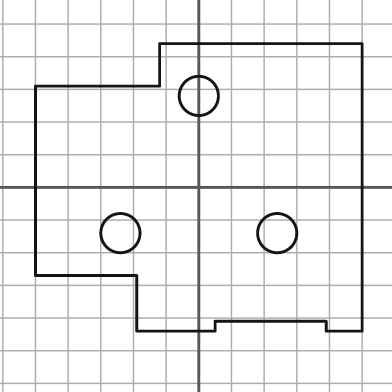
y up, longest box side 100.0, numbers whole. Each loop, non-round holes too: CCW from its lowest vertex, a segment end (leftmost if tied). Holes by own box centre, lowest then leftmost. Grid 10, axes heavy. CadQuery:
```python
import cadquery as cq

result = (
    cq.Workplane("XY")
    .moveTo(-19.0, -44.0)
    .lineTo(5.0, -44.0)
    .lineTo(5.0, -41.0)
    .lineTo(39.0, -41.0)
    .lineTo(39.0, -44.0)
    .lineTo(50.0, -44.0)
    .lineTo(50.0, 44.0)
    .lineTo(-12.0, 44.0)
    .lineTo(-12.0, 31.0)
    .lineTo(-50.0, 31.0)
    .lineTo(-50.0, -27.0)
    .lineTo(-19.0, -27.0)
    .close()
    .moveTo(-24.0, -14.0)
    .circle(6.0)
    .moveTo(24.0, -14.0)
    .circle(6.0)
    .moveTo(0.0, 28.0)
    .circle(6.0)
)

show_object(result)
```